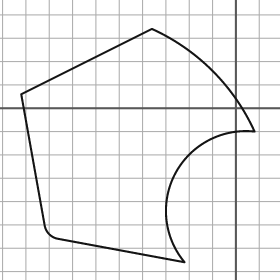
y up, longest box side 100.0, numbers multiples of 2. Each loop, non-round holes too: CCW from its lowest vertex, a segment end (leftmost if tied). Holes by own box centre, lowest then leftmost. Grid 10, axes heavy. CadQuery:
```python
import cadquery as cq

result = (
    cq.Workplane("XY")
    .moveTo(-22.0, -66.0)
    .threePointArc((-26.0, -28.0), (8.0, -10.0))
    .threePointArc((-10.0, 16.0), (-36.0, 34.0))
    .lineTo(-92.0, 6.0)
    .lineTo(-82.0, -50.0)
    .threePointArc((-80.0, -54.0), (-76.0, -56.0))
    .close()
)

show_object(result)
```